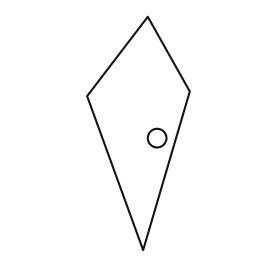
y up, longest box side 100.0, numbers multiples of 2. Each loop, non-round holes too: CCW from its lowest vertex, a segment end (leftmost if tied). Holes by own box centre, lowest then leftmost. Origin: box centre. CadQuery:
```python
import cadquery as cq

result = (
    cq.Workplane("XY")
    .moveTo(2.0, -50.0)
    .lineTo(22.0, 18.0)
    .lineTo(4.0, 50.0)
    .lineTo(-22.0, 16.0)
    .close()
    .moveTo(8.0, -2.0)
    .circle(4.0)
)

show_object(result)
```